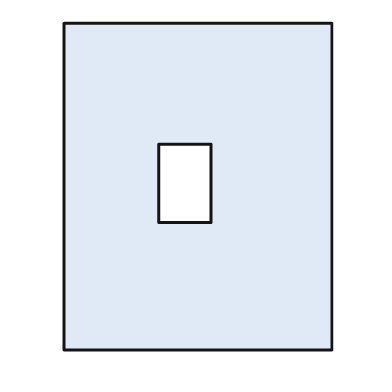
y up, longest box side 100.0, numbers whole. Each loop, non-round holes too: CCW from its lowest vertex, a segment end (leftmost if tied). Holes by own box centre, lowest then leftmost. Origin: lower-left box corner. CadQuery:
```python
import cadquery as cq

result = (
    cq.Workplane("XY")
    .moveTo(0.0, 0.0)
    .lineTo(82.0, 0.0)
    .lineTo(82.0, 100.0)
    .lineTo(0.0, 100.0)
    .close()
    .moveTo(29.0, 39.0)
    .lineTo(45.0, 39.0)
    .lineTo(45.0, 63.0)
    .lineTo(29.0, 63.0)
    .close()
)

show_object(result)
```